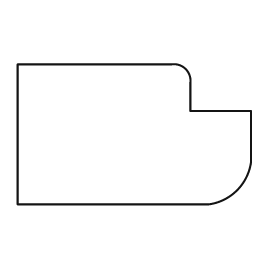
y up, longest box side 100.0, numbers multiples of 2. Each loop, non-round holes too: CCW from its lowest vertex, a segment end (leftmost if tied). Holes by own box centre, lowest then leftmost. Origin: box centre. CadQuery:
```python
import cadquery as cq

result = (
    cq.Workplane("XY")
    .moveTo(-50.0, -30.0)
    .lineTo(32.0, -30.0)
    .threePointArc((44.0, -24.0), (50.0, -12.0))
    .lineTo(50.0, 10.0)
    .lineTo(24.0, 10.0)
    .lineTo(24.0, 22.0)
    .threePointArc((22.0, 28.0), (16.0, 30.0))
    .lineTo(-50.0, 30.0)
    .close()
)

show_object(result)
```